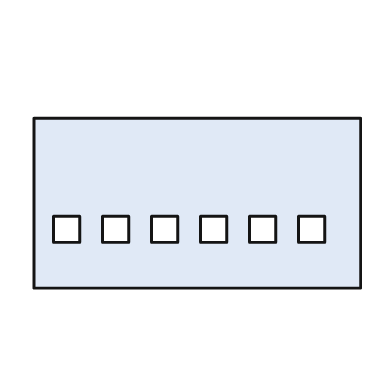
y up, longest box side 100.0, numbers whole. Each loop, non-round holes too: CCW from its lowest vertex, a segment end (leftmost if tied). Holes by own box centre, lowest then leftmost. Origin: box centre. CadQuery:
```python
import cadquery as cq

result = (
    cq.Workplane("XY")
    .moveTo(-50.0, -26.0)
    .lineTo(50.0, -26.0)
    .lineTo(50.0, 26.0)
    .lineTo(-50.0, 26.0)
    .close()
    .moveTo(-44.0, -12.0)
    .lineTo(-36.0, -12.0)
    .lineTo(-36.0, -4.0)
    .lineTo(-44.0, -4.0)
    .close()
    .moveTo(-29.0, -12.0)
    .lineTo(-21.0, -12.0)
    .lineTo(-21.0, -4.0)
    .lineTo(-29.0, -4.0)
    .close()
    .moveTo(-14.0, -12.0)
    .lineTo(-6.0, -12.0)
    .lineTo(-6.0, -4.0)
    .lineTo(-14.0, -4.0)
    .close()
    .moveTo(1.0, -12.0)
    .lineTo(9.0, -12.0)
    .lineTo(9.0, -4.0)
    .lineTo(1.0, -4.0)
    .close()
    .moveTo(16.0, -12.0)
    .lineTo(24.0, -12.0)
    .lineTo(24.0, -4.0)
    .lineTo(16.0, -4.0)
    .close()
    .moveTo(31.0, -12.0)
    .lineTo(39.0, -12.0)
    .lineTo(39.0, -4.0)
    .lineTo(31.0, -4.0)
    .close()
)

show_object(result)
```